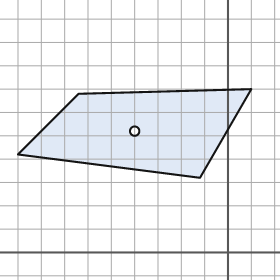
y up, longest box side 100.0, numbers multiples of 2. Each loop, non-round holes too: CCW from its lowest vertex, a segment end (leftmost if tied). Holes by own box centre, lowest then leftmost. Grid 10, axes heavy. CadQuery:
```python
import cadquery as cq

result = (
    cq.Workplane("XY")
    .moveTo(-12.0, 32.0)
    .lineTo(10.0, 70.0)
    .lineTo(-64.0, 68.0)
    .lineTo(-90.0, 42.0)
    .close()
    .moveTo(-40.0, 52.0)
    .circle(2.0)
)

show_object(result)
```